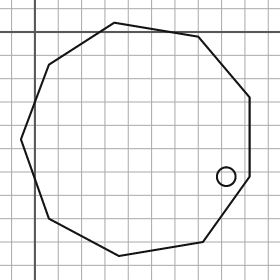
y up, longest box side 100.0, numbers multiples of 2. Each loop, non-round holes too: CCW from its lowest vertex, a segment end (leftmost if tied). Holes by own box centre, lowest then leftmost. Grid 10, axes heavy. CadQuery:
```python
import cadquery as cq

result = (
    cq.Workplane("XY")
    .moveTo(36.0, -96.0)
    .lineTo(72.0, -90.0)
    .lineTo(92.0, -62.0)
    .lineTo(92.0, -28.0)
    .lineTo(70.0, -2.0)
    .lineTo(34.0, 4.0)
    .lineTo(6.0, -14.0)
    .lineTo(-6.0, -46.0)
    .lineTo(6.0, -80.0)
    .close()
    .moveTo(82.0, -62.0)
    .circle(4.0)
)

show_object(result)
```